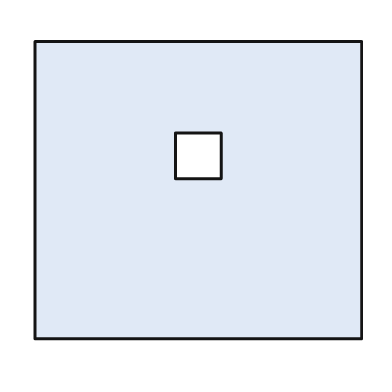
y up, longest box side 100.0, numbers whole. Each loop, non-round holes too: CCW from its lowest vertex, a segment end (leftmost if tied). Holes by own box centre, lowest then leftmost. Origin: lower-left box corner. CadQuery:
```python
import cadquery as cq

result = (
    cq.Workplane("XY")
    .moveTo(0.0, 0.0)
    .lineTo(100.0, 0.0)
    .lineTo(100.0, 91.0)
    .lineTo(0.0, 91.0)
    .close()
    .moveTo(43.0, 49.0)
    .lineTo(57.0, 49.0)
    .lineTo(57.0, 63.0)
    .lineTo(43.0, 63.0)
    .close()
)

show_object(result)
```